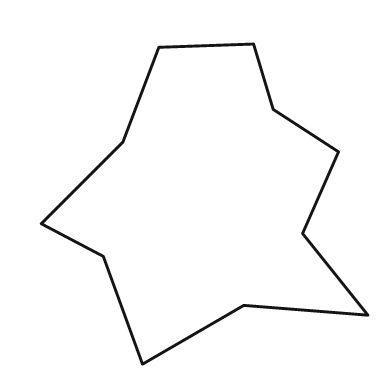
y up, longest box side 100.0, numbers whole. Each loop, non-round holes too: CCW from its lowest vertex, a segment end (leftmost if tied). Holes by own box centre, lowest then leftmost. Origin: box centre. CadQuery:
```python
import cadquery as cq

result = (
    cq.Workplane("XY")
    .moveTo(-19.0, -49.0)
    .lineTo(12.0, -31.0)
    .lineTo(50.0, -34.0)
    .lineTo(30.0, -9.0)
    .lineTo(41.0, 16.0)
    .lineTo(21.0, 29.0)
    .lineTo(15.0, 49.0)
    .lineTo(-14.0, 48.0)
    .lineTo(-25.0, 19.0)
    .lineTo(-50.0, -6.0)
    .lineTo(-31.0, -16.0)
    .close()
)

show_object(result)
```